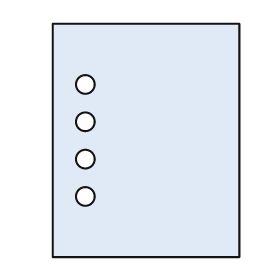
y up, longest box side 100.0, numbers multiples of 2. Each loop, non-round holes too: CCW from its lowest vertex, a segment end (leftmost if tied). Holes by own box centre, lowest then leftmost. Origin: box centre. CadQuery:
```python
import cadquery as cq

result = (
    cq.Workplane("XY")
    .moveTo(-40.0, -50.0)
    .lineTo(40.0, -50.0)
    .lineTo(40.0, 50.0)
    .lineTo(-40.0, 50.0)
    .close()
    .moveTo(-26.0, -24.0)
    .circle(4.0)
    .moveTo(-26.0, -8.0)
    .circle(4.0)
    .moveTo(-26.0, 8.0)
    .circle(4.0)
    .moveTo(-26.0, 24.0)
    .circle(4.0)
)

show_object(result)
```